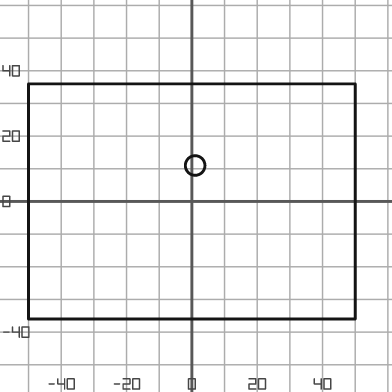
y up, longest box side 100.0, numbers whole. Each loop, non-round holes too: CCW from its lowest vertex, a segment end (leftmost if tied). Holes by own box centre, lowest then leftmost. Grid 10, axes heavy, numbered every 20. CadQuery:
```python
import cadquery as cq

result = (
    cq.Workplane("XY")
    .moveTo(-50.0, -36.0)
    .lineTo(50.0, -36.0)
    .lineTo(50.0, 36.0)
    .lineTo(-50.0, 36.0)
    .close()
    .moveTo(1.0, 11.0)
    .circle(3.0)
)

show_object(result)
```